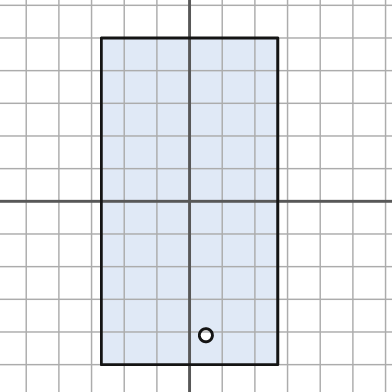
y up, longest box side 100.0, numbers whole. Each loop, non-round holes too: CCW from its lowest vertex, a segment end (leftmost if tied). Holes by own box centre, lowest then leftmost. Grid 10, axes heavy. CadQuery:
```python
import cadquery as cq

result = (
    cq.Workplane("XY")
    .moveTo(-27.0, -50.0)
    .lineTo(27.0, -50.0)
    .lineTo(27.0, 50.0)
    .lineTo(-27.0, 50.0)
    .close()
    .moveTo(5.0, -41.0)
    .circle(2.0)
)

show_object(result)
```